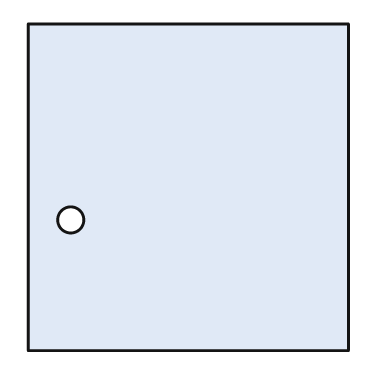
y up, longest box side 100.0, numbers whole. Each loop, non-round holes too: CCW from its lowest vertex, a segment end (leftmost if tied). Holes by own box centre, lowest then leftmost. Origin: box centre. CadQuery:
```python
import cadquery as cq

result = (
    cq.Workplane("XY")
    .moveTo(-49.0, -50.0)
    .lineTo(49.0, -50.0)
    .lineTo(49.0, 50.0)
    .lineTo(-49.0, 50.0)
    .close()
    .moveTo(-36.0, -10.0)
    .circle(4.0)
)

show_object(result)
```